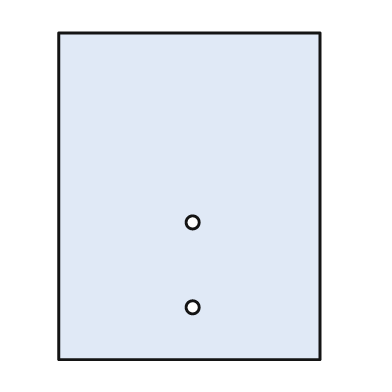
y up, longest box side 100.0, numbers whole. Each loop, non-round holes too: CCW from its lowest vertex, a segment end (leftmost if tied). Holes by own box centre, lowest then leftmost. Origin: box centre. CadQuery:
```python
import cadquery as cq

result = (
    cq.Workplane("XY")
    .moveTo(-40.0, -50.0)
    .lineTo(40.0, -50.0)
    .lineTo(40.0, 50.0)
    .lineTo(-40.0, 50.0)
    .close()
    .moveTo(1.0, -34.0)
    .circle(2.0)
    .moveTo(1.0, -8.0)
    .circle(2.0)
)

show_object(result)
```